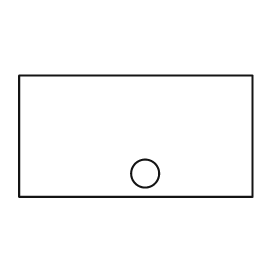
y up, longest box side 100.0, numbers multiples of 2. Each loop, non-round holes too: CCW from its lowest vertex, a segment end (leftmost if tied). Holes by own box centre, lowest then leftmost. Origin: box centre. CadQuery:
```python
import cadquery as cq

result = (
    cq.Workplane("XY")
    .moveTo(-50.0, -26.0)
    .lineTo(50.0, -26.0)
    .lineTo(50.0, 26.0)
    .lineTo(-50.0, 26.0)
    .close()
    .moveTo(4.0, -16.0)
    .circle(6.0)
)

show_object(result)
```